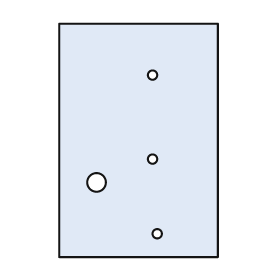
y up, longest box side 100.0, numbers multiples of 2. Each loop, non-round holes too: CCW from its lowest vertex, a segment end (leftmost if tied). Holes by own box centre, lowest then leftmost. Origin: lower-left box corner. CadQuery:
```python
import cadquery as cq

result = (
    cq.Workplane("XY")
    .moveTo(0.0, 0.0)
    .lineTo(68.0, 0.0)
    .lineTo(68.0, 100.0)
    .lineTo(0.0, 100.0)
    .close()
    .moveTo(42.0, 10.0)
    .circle(2.0)
    .moveTo(16.0, 32.0)
    .circle(4.0)
    .moveTo(40.0, 42.0)
    .circle(2.0)
    .moveTo(40.0, 78.0)
    .circle(2.0)
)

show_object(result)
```